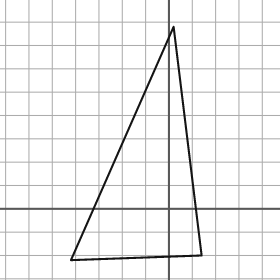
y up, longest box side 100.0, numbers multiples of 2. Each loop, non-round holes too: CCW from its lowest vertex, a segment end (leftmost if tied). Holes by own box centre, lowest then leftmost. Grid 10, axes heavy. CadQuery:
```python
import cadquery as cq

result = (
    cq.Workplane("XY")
    .moveTo(-42.0, -22.0)
    .lineTo(14.0, -20.0)
    .lineTo(2.0, 78.0)
    .close()
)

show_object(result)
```